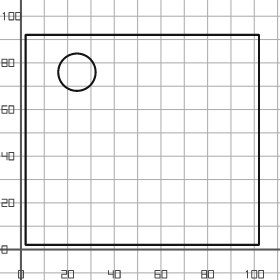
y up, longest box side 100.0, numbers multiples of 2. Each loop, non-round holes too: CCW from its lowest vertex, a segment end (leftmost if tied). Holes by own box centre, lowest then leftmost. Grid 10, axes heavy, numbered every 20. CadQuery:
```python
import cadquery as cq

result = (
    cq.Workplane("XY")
    .moveTo(2.0, 2.0)
    .lineTo(102.0, 2.0)
    .lineTo(102.0, 92.0)
    .lineTo(2.0, 92.0)
    .close()
    .moveTo(24.0, 76.0)
    .circle(8.0)
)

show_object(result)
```